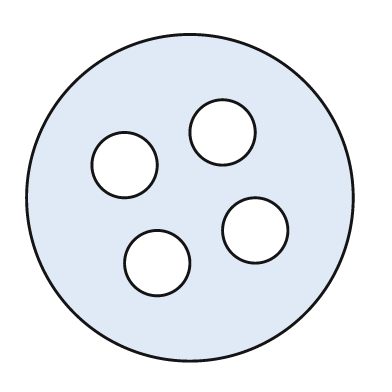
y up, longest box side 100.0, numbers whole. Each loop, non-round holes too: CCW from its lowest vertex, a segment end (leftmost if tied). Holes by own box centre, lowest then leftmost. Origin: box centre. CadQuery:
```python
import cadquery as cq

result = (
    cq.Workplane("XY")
    .moveTo(0.0, 0.0)
    .circle(50.0)
    .moveTo(-10.0, -20.0)
    .circle(10.0)
    .moveTo(20.0, -10.0)
    .circle(10.0)
    .moveTo(-20.0, 10.0)
    .circle(10.0)
    .moveTo(10.0, 20.0)
    .circle(10.0)
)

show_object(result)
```